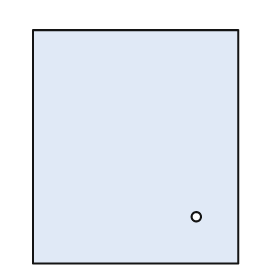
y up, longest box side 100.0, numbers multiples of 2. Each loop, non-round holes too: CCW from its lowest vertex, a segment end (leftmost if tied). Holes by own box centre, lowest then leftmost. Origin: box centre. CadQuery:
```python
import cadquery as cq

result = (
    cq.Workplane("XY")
    .moveTo(-44.0, -50.0)
    .lineTo(44.0, -50.0)
    .lineTo(44.0, 50.0)
    .lineTo(-44.0, 50.0)
    .close()
    .moveTo(26.0, -30.0)
    .circle(2.0)
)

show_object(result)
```